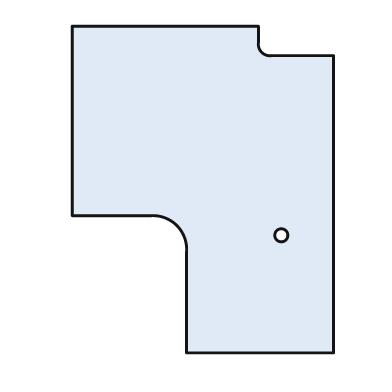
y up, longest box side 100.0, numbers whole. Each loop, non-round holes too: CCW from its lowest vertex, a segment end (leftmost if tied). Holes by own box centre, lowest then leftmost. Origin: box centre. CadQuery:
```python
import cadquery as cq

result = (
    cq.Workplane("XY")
    .moveTo(-5.0, -50.0)
    .lineTo(40.0, -50.0)
    .lineTo(40.0, 41.0)
    .lineTo(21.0, 41.0)
    .threePointArc((18.0, 42.0), (17.0, 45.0))
    .lineTo(17.0, 50.0)
    .lineTo(-40.0, 50.0)
    .lineTo(-40.0, -8.0)
    .lineTo(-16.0, -8.0)
    .threePointArc((-8.0, -11.0), (-5.0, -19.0))
    .close()
    .moveTo(24.0, -14.0)
    .circle(2.0)
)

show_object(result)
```